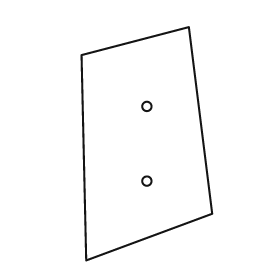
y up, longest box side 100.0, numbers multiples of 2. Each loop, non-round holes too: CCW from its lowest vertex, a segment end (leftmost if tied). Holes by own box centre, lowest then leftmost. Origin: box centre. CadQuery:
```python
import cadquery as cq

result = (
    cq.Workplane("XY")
    .moveTo(-26.0, -50.0)
    .lineTo(28.0, -30.0)
    .lineTo(18.0, 50.0)
    .lineTo(-28.0, 38.0)
    .close()
    .moveTo(0.0, -16.0)
    .circle(2.0)
    .moveTo(0.0, 16.0)
    .circle(2.0)
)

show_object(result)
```